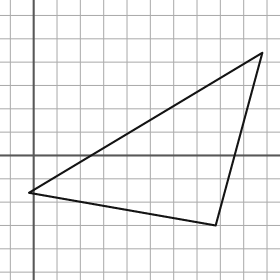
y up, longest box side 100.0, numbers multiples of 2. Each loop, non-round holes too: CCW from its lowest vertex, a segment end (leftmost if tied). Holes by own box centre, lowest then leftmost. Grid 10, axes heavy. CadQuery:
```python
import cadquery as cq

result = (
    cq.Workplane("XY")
    .moveTo(78.0, -30.0)
    .lineTo(98.0, 44.0)
    .lineTo(-2.0, -16.0)
    .close()
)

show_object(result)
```